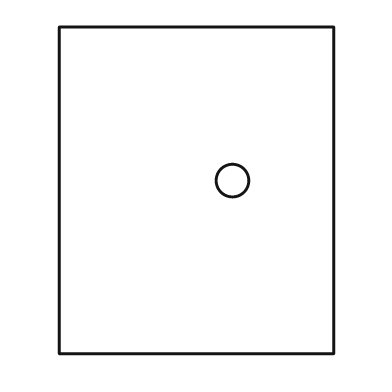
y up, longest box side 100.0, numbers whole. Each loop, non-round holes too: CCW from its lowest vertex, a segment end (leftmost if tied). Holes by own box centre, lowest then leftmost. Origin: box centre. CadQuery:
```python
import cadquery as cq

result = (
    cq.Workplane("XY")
    .moveTo(-42.0, -50.0)
    .lineTo(42.0, -50.0)
    .lineTo(42.0, 50.0)
    .lineTo(-42.0, 50.0)
    .close()
    .moveTo(11.0, 3.0)
    .circle(5.0)
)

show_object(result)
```